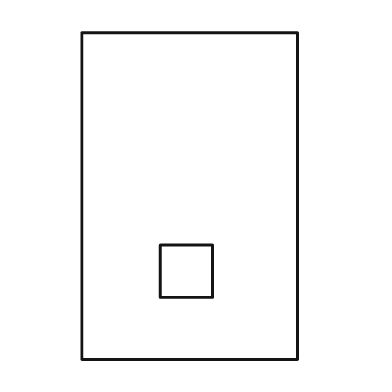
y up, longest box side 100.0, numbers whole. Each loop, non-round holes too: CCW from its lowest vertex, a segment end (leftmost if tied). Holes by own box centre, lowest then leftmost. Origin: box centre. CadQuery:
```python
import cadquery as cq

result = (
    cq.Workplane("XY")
    .moveTo(-33.0, -50.0)
    .lineTo(33.0, -50.0)
    .lineTo(33.0, 50.0)
    .lineTo(-33.0, 50.0)
    .close()
    .moveTo(-9.0, -31.0)
    .lineTo(7.0, -31.0)
    .lineTo(7.0, -15.0)
    .lineTo(-9.0, -15.0)
    .close()
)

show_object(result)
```